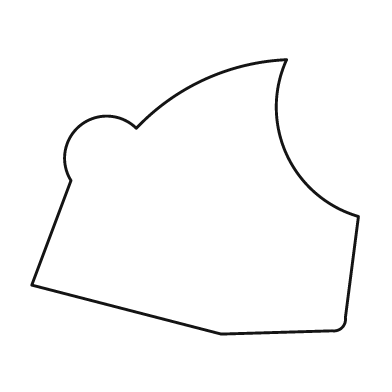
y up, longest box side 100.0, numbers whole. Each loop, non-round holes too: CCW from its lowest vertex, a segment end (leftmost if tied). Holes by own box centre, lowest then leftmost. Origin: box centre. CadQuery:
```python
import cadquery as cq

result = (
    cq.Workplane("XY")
    .moveTo(8.0, -42.0)
    .lineTo(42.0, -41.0)
    .threePointArc((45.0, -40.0), (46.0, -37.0))
    .lineTo(50.0, -6.0)
    .threePointArc((28.0, 13.0), (28.0, 42.0))
    .threePointArc((3.0, 36.0), (-18.0, 21.0))
    .threePointArc((-35.0, 22.0), (-38.0, 5.0))
    .lineTo(-50.0, -27.0)
    .close()
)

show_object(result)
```